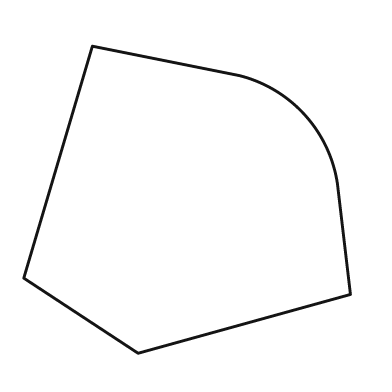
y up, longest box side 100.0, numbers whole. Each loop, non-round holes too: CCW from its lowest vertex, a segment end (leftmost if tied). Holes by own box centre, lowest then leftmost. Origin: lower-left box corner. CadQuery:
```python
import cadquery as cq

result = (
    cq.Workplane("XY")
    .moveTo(35.0, 0.0)
    .lineTo(100.0, 18.0)
    .lineTo(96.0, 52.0)
    .threePointArc((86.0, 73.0), (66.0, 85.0))
    .lineTo(21.0, 94.0)
    .lineTo(0.0, 23.0)
    .close()
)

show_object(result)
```